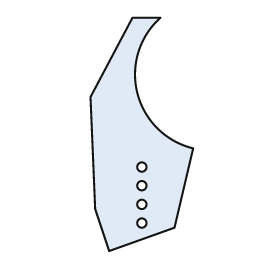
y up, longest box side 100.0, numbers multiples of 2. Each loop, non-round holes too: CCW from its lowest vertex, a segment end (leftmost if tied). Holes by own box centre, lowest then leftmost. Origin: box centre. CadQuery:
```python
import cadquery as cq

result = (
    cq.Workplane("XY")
    .moveTo(-14.0, -50.0)
    .lineTo(14.0, -40.0)
    .lineTo(22.0, -6.0)
    .threePointArc((-2.0, 18.0), (8.0, 50.0))
    .lineTo(-4.0, 50.0)
    .lineTo(-22.0, 16.0)
    .lineTo(-20.0, -32.0)
    .close()
    .moveTo(0.0, -38.0)
    .circle(2.0)
    .moveTo(0.0, -30.0)
    .circle(2.0)
    .moveTo(0.0, -22.0)
    .circle(2.0)
    .moveTo(0.0, -14.0)
    .circle(2.0)
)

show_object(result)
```